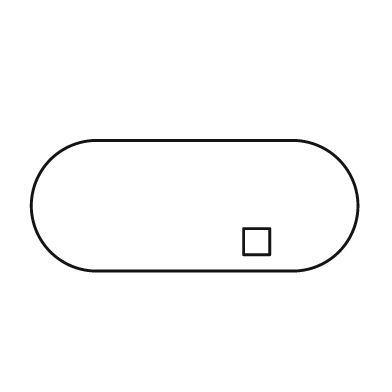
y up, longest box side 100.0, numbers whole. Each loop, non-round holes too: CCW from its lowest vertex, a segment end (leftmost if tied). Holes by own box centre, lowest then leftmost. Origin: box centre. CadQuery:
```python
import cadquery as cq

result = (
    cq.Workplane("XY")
    .moveTo(-30.0, -20.0)
    .lineTo(30.0, -20.0)
    .threePointArc((50.0, 0.0), (30.0, 20.0))
    .lineTo(-30.0, 20.0)
    .threePointArc((-50.0, 0.0), (-30.0, -20.0))
    .close()
    .moveTo(15.0, -15.0)
    .lineTo(23.0, -15.0)
    .lineTo(23.0, -7.0)
    .lineTo(15.0, -7.0)
    .close()
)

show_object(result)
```